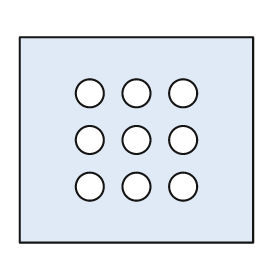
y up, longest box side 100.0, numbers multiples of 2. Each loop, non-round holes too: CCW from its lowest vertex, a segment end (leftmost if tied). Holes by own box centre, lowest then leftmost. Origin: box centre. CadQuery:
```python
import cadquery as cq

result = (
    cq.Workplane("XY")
    .moveTo(-50.0, -44.0)
    .lineTo(50.0, -44.0)
    .lineTo(50.0, 44.0)
    .lineTo(-50.0, 44.0)
    .close()
    .moveTo(-20.0, -20.0)
    .circle(6.0)
    .moveTo(0.0, -20.0)
    .circle(6.0)
    .moveTo(20.0, -20.0)
    .circle(6.0)
    .moveTo(-20.0, 0.0)
    .circle(6.0)
    .moveTo(0.0, 0.0)
    .circle(6.0)
    .moveTo(20.0, 0.0)
    .circle(6.0)
    .moveTo(-20.0, 20.0)
    .circle(6.0)
    .moveTo(0.0, 20.0)
    .circle(6.0)
    .moveTo(20.0, 20.0)
    .circle(6.0)
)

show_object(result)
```